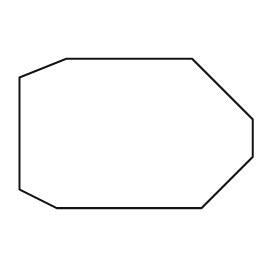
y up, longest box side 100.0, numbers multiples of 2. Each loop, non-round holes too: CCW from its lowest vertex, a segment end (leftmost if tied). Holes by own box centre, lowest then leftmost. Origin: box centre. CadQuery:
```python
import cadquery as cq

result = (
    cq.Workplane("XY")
    .moveTo(-34.0, -32.0)
    .lineTo(28.0, -32.0)
    .lineTo(50.0, -10.0)
    .lineTo(50.0, 6.0)
    .lineTo(24.0, 32.0)
    .lineTo(-30.0, 32.0)
    .lineTo(-50.0, 24.0)
    .lineTo(-50.0, -24.0)
    .close()
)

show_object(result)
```